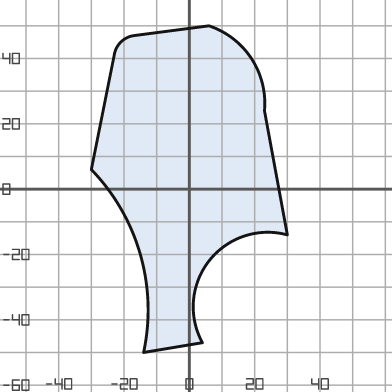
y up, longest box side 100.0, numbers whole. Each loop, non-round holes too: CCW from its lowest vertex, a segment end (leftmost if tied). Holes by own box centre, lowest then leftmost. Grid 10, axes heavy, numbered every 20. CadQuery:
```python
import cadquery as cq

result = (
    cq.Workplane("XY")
    .moveTo(-14.0, -50.0)
    .lineTo(4.0, -47.0)
    .threePointArc((6.0, -22.0), (30.0, -14.0))
    .lineTo(23.0, 24.0)
    .threePointArc((19.0, 40.0), (6.0, 50.0))
    .lineTo(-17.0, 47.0)
    .threePointArc((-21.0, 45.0), (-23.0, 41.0))
    .lineTo(-30.0, 6.0)
    .threePointArc((-15.0, -20.0), (-14.0, -50.0))
    .close()
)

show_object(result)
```